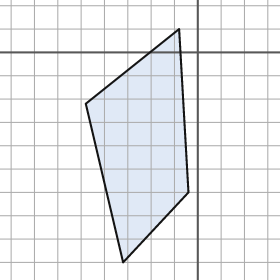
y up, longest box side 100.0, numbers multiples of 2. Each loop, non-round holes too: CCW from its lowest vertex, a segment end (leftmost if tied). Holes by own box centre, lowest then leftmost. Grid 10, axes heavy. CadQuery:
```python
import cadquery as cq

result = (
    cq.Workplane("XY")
    .moveTo(-32.0, -90.0)
    .lineTo(-4.0, -60.0)
    .lineTo(-8.0, 10.0)
    .lineTo(-48.0, -22.0)
    .close()
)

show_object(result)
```